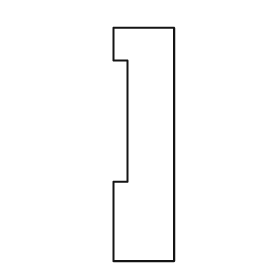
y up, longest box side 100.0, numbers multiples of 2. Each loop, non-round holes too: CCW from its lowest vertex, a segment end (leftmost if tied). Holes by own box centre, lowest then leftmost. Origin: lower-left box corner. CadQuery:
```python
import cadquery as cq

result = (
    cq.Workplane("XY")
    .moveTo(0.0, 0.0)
    .lineTo(26.0, 0.0)
    .lineTo(26.0, 100.0)
    .lineTo(0.0, 100.0)
    .lineTo(0.0, 86.0)
    .lineTo(6.0, 86.0)
    .lineTo(6.0, 34.0)
    .lineTo(0.0, 34.0)
    .close()
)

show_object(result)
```